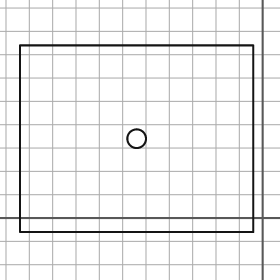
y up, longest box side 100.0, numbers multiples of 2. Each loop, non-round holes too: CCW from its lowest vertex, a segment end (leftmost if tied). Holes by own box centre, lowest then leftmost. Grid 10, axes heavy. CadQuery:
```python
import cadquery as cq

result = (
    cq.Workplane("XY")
    .moveTo(-104.0, -6.0)
    .lineTo(-4.0, -6.0)
    .lineTo(-4.0, 74.0)
    .lineTo(-104.0, 74.0)
    .close()
    .moveTo(-54.0, 34.0)
    .circle(4.0)
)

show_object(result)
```